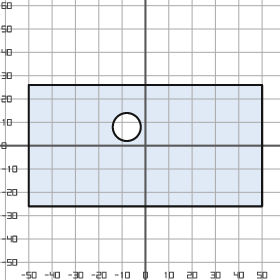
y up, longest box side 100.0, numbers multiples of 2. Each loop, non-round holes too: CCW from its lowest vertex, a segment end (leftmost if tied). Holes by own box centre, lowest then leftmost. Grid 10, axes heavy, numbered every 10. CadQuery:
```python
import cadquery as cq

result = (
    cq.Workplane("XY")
    .moveTo(-50.0, -26.0)
    .lineTo(50.0, -26.0)
    .lineTo(50.0, 26.0)
    .lineTo(-50.0, 26.0)
    .close()
    .moveTo(-8.0, 8.0)
    .circle(6.0)
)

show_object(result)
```